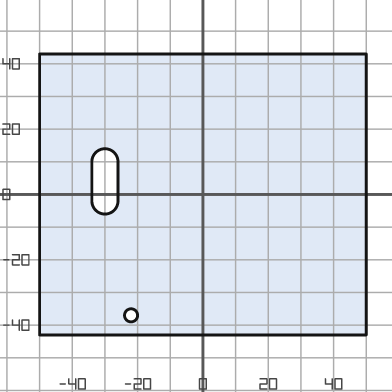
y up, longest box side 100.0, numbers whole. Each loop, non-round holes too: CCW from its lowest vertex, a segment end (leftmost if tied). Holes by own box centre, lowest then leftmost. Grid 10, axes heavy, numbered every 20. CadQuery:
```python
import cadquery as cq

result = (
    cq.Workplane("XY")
    .moveTo(-50.0, -43.0)
    .lineTo(50.0, -43.0)
    .lineTo(50.0, 43.0)
    .lineTo(-50.0, 43.0)
    .close()
    .moveTo(-22.0, -37.0)
    .circle(2.0)
    .moveTo(-34.0, -2.0)
    .threePointArc((-30.0, -6.0), (-26.0, -2.0))
    .lineTo(-26.0, 10.0)
    .threePointArc((-30.0, 14.0), (-34.0, 10.0))
    .close()
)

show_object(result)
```